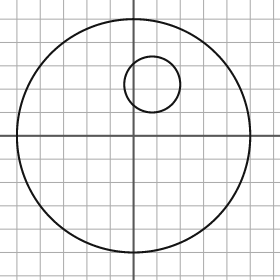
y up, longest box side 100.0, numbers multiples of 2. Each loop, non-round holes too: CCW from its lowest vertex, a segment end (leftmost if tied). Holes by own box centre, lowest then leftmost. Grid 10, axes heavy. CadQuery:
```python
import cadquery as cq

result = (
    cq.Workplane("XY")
    .moveTo(0.0, 0.0)
    .circle(50.0)
    .moveTo(8.0, 22.0)
    .circle(12.0)
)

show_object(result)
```